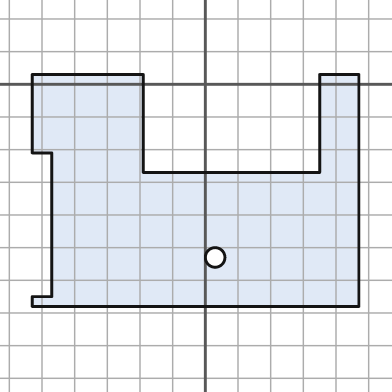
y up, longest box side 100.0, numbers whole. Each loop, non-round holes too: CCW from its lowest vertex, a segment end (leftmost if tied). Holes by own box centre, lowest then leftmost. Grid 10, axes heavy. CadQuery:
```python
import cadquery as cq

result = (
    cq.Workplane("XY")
    .moveTo(-53.0, -68.0)
    .lineTo(47.0, -68.0)
    .lineTo(47.0, 3.0)
    .lineTo(35.0, 3.0)
    .lineTo(35.0, -27.0)
    .lineTo(-19.0, -27.0)
    .lineTo(-19.0, 3.0)
    .lineTo(-53.0, 3.0)
    .lineTo(-53.0, -21.0)
    .lineTo(-47.0, -21.0)
    .lineTo(-47.0, -65.0)
    .lineTo(-53.0, -65.0)
    .close()
    .moveTo(3.0, -53.0)
    .circle(3.0)
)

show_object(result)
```